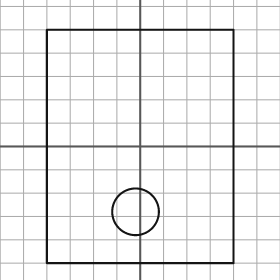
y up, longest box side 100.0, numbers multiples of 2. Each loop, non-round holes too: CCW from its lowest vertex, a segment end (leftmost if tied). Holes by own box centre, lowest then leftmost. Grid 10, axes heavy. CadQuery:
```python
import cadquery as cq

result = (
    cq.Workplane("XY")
    .moveTo(-40.0, -50.0)
    .lineTo(40.0, -50.0)
    .lineTo(40.0, 50.0)
    .lineTo(-40.0, 50.0)
    .close()
    .moveTo(-2.0, -28.0)
    .circle(10.0)
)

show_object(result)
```